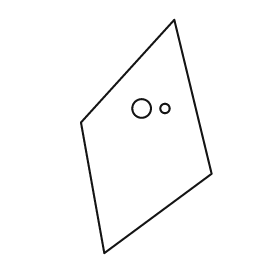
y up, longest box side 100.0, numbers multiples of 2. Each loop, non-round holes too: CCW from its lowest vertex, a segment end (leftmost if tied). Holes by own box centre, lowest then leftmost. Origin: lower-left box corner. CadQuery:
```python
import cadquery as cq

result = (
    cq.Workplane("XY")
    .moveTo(10.0, 0.0)
    .lineTo(56.0, 34.0)
    .lineTo(40.0, 100.0)
    .lineTo(0.0, 56.0)
    .close()
    .moveTo(26.0, 62.0)
    .circle(4.0)
    .moveTo(36.0, 62.0)
    .circle(2.0)
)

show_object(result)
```